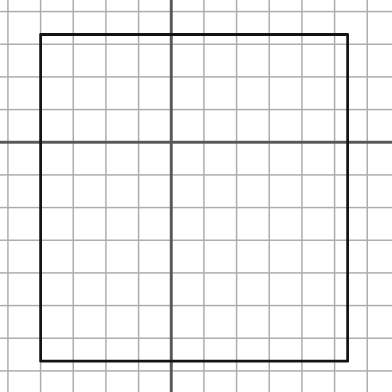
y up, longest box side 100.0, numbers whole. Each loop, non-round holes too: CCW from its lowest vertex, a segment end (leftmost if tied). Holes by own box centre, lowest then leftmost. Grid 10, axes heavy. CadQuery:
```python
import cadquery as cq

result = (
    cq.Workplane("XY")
    .moveTo(-40.0, -67.0)
    .lineTo(54.0, -67.0)
    .lineTo(54.0, 33.0)
    .lineTo(-40.0, 33.0)
    .close()
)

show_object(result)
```